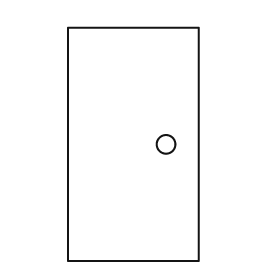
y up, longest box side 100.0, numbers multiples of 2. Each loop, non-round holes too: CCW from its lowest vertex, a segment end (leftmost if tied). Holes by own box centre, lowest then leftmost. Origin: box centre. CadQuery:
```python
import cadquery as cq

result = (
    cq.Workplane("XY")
    .moveTo(-28.0, -50.0)
    .lineTo(28.0, -50.0)
    .lineTo(28.0, 50.0)
    .lineTo(-28.0, 50.0)
    .close()
    .moveTo(14.0, 0.0)
    .circle(4.0)
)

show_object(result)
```